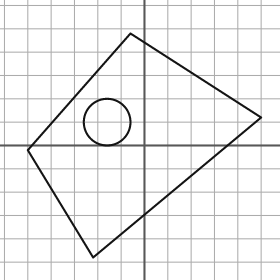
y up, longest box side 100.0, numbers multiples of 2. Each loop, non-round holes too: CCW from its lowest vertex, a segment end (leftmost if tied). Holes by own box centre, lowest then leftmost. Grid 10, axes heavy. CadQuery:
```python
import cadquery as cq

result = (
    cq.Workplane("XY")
    .moveTo(-22.0, -48.0)
    .lineTo(50.0, 12.0)
    .lineTo(-6.0, 48.0)
    .lineTo(-50.0, -2.0)
    .close()
    .moveTo(-16.0, 10.0)
    .circle(10.0)
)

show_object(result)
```